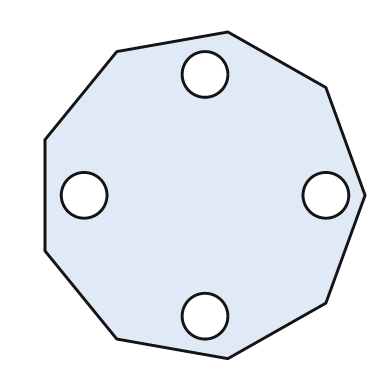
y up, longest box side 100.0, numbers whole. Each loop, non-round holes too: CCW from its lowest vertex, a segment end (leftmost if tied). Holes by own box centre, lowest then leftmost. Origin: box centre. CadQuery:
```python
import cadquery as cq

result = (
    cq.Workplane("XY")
    .moveTo(7.0, -50.0)
    .lineTo(37.0, -33.0)
    .lineTo(49.0, 0.0)
    .lineTo(37.0, 33.0)
    .lineTo(7.0, 50.0)
    .lineTo(-27.0, 44.0)
    .lineTo(-49.0, 17.0)
    .lineTo(-49.0, -17.0)
    .lineTo(-27.0, -44.0)
    .close()
    .moveTo(0.0, -37.0)
    .circle(7.0)
    .moveTo(-37.0, 0.0)
    .circle(7.0)
    .moveTo(37.0, 0.0)
    .circle(7.0)
    .moveTo(0.0, 37.0)
    .circle(7.0)
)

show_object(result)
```